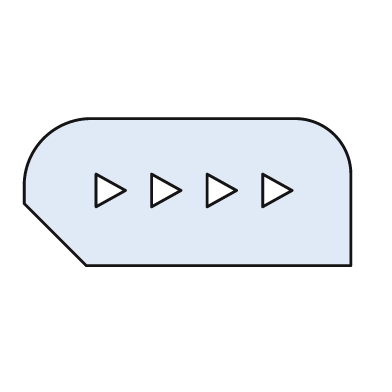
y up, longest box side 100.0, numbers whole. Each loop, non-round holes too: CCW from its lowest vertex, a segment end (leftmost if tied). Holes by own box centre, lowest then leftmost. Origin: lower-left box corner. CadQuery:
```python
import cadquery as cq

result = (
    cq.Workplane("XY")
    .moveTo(19.0, 0.0)
    .lineTo(100.0, 0.0)
    .lineTo(100.0, 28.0)
    .threePointArc((95.0, 40.0), (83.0, 45.0))
    .lineTo(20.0, 45.0)
    .threePointArc((6.0, 39.0), (0.0, 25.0))
    .lineTo(0.0, 19.0)
    .close()
    .moveTo(22.0, 18.0)
    .lineTo(31.0, 23.0)
    .lineTo(22.0, 28.0)
    .close()
    .moveTo(39.0, 18.0)
    .lineTo(48.0, 23.0)
    .lineTo(39.0, 28.0)
    .close()
    .moveTo(56.0, 18.0)
    .lineTo(65.0, 23.0)
    .lineTo(56.0, 28.0)
    .close()
    .moveTo(73.0, 18.0)
    .lineTo(82.0, 23.0)
    .lineTo(73.0, 28.0)
    .close()
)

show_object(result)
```